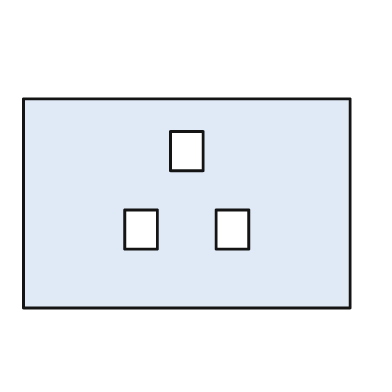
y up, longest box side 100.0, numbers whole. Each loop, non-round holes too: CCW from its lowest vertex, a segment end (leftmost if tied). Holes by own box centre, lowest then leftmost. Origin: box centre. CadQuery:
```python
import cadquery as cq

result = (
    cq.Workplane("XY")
    .moveTo(-50.0, -32.0)
    .lineTo(50.0, -32.0)
    .lineTo(50.0, 32.0)
    .lineTo(-50.0, 32.0)
    .close()
    .moveTo(-19.0, -14.0)
    .lineTo(-9.0, -14.0)
    .lineTo(-9.0, -2.0)
    .lineTo(-19.0, -2.0)
    .close()
    .moveTo(9.0, -14.0)
    .lineTo(19.0, -14.0)
    .lineTo(19.0, -2.0)
    .lineTo(9.0, -2.0)
    .close()
    .moveTo(-5.0, 10.0)
    .lineTo(5.0, 10.0)
    .lineTo(5.0, 22.0)
    .lineTo(-5.0, 22.0)
    .close()
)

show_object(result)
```